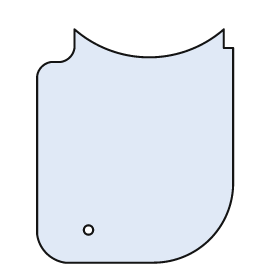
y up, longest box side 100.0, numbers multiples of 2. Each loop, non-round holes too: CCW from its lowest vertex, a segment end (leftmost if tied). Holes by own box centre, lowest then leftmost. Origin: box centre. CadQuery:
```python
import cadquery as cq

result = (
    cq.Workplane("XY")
    .moveTo(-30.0, -50.0)
    .lineTo(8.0, -50.0)
    .threePointArc((32.0, -40.0), (42.0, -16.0))
    .lineTo(42.0, 42.0)
    .lineTo(38.0, 42.0)
    .lineTo(38.0, 50.0)
    .threePointArc((6.0, 38.0), (-26.0, 50.0))
    .lineTo(-26.0, 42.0)
    .threePointArc((-28.0, 38.0), (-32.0, 36.0))
    .lineTo(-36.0, 36.0)
    .threePointArc((-40.0, 34.0), (-42.0, 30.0))
    .lineTo(-42.0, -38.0)
    .threePointArc((-38.0, -46.0), (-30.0, -50.0))
    .close()
    .moveTo(-20.0, -36.0)
    .circle(2.0)
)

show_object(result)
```